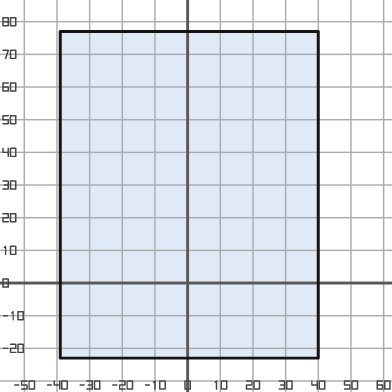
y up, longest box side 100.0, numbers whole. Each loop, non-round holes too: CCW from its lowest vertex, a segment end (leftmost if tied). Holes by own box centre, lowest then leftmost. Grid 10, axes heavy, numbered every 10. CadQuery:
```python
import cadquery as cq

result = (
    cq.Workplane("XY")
    .moveTo(-39.0, -23.0)
    .lineTo(40.0, -23.0)
    .lineTo(40.0, 77.0)
    .lineTo(-39.0, 77.0)
    .close()
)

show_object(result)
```